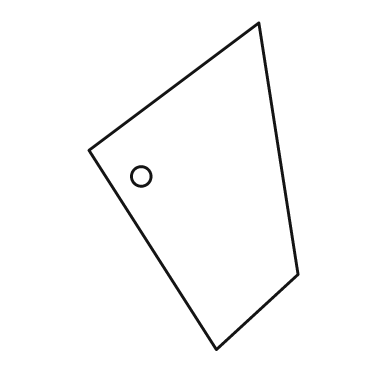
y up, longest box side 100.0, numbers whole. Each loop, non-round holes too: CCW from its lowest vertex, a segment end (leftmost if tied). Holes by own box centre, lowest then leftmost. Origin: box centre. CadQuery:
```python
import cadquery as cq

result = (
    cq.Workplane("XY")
    .moveTo(7.0, -50.0)
    .lineTo(32.0, -27.0)
    .lineTo(20.0, 50.0)
    .lineTo(-32.0, 11.0)
    .close()
    .moveTo(-16.0, 3.0)
    .circle(3.0)
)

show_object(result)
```